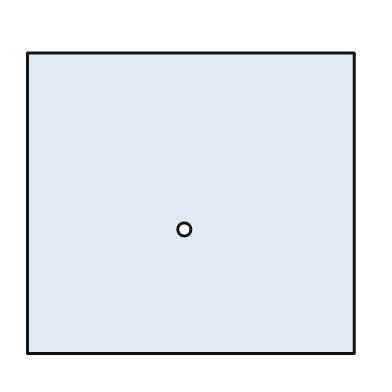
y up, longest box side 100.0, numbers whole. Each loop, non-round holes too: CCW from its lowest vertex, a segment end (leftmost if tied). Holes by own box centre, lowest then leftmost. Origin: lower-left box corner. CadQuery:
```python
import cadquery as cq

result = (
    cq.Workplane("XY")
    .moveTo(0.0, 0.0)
    .lineTo(100.0, 0.0)
    .lineTo(100.0, 92.0)
    .lineTo(0.0, 92.0)
    .close()
    .moveTo(48.0, 38.0)
    .circle(2.0)
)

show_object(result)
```